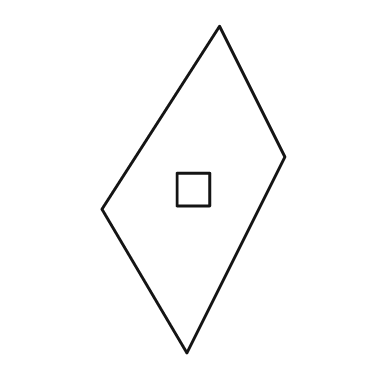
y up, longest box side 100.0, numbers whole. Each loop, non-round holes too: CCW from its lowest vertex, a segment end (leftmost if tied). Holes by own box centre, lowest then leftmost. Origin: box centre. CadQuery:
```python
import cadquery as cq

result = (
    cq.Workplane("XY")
    .moveTo(-2.0, -50.0)
    .lineTo(28.0, 10.0)
    .lineTo(8.0, 50.0)
    .lineTo(-28.0, -6.0)
    .close()
    .moveTo(-5.0, -5.0)
    .lineTo(5.0, -5.0)
    .lineTo(5.0, 5.0)
    .lineTo(-5.0, 5.0)
    .close()
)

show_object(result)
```